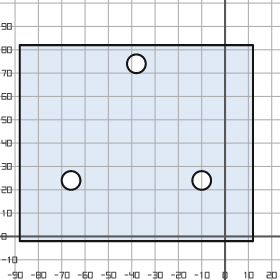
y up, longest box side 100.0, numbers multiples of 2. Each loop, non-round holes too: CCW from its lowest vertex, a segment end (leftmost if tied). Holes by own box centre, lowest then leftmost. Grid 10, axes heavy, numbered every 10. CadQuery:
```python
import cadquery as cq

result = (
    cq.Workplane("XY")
    .moveTo(-88.0, -2.0)
    .lineTo(12.0, -2.0)
    .lineTo(12.0, 82.0)
    .lineTo(-88.0, 82.0)
    .close()
    .moveTo(-66.0, 24.0)
    .circle(4.0)
    .moveTo(-10.0, 24.0)
    .circle(4.0)
    .moveTo(-38.0, 74.0)
    .circle(4.0)
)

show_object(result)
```